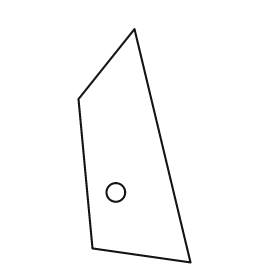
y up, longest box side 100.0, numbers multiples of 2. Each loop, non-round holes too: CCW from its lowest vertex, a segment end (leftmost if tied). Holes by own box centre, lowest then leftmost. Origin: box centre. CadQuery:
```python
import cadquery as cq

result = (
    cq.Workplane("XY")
    .moveTo(24.0, -50.0)
    .lineTo(0.0, 50.0)
    .lineTo(-24.0, 20.0)
    .lineTo(-18.0, -44.0)
    .close()
    .moveTo(-8.0, -20.0)
    .circle(4.0)
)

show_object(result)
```